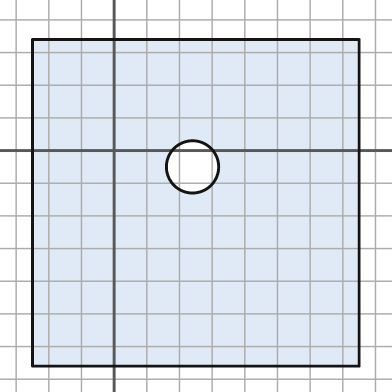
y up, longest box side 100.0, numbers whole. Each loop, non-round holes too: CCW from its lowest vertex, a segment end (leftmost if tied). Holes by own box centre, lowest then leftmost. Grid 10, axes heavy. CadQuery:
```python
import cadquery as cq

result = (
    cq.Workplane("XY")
    .moveTo(-25.0, -66.0)
    .lineTo(75.0, -66.0)
    .lineTo(75.0, 34.0)
    .lineTo(-25.0, 34.0)
    .close()
    .moveTo(24.0, -5.0)
    .circle(8.0)
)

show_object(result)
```